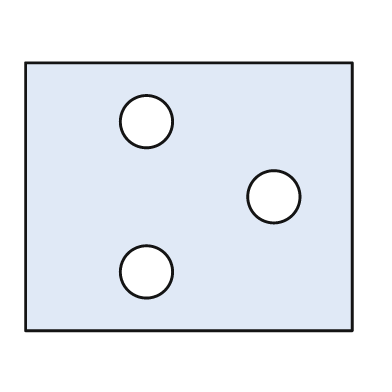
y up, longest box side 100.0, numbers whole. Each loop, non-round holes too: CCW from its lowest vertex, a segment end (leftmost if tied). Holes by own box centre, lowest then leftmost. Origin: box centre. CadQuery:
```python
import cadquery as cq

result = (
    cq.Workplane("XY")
    .moveTo(-50.0, -41.0)
    .lineTo(50.0, -41.0)
    .lineTo(50.0, 41.0)
    .lineTo(-50.0, 41.0)
    .close()
    .moveTo(-13.0, -23.0)
    .circle(8.0)
    .moveTo(26.0, 0.0)
    .circle(8.0)
    .moveTo(-13.0, 23.0)
    .circle(8.0)
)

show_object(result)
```